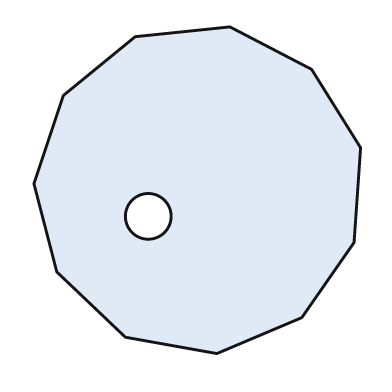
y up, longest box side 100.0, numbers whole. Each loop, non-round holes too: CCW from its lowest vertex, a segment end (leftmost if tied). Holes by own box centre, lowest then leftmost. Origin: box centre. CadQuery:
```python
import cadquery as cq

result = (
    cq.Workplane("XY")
    .moveTo(6.0, -50.0)
    .lineTo(32.0, -39.0)
    .lineTo(48.0, -16.0)
    .lineTo(50.0, 13.0)
    .lineTo(35.0, 37.0)
    .lineTo(10.0, 50.0)
    .lineTo(-19.0, 47.0)
    .lineTo(-41.0, 29.0)
    .lineTo(-50.0, 2.0)
    .lineTo(-43.0, -25.0)
    .lineTo(-22.0, -45.0)
    .close()
    .moveTo(-15.0, -8.0)
    .circle(7.0)
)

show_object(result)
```